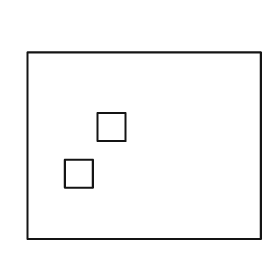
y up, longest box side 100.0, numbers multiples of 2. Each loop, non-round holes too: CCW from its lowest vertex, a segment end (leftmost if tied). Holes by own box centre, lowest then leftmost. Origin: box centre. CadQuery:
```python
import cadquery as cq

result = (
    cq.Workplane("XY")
    .moveTo(-50.0, -40.0)
    .lineTo(50.0, -40.0)
    .lineTo(50.0, 40.0)
    .lineTo(-50.0, 40.0)
    .close()
    .moveTo(-34.0, -18.0)
    .lineTo(-22.0, -18.0)
    .lineTo(-22.0, -6.0)
    .lineTo(-34.0, -6.0)
    .close()
    .moveTo(-20.0, 2.0)
    .lineTo(-8.0, 2.0)
    .lineTo(-8.0, 14.0)
    .lineTo(-20.0, 14.0)
    .close()
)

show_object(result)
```